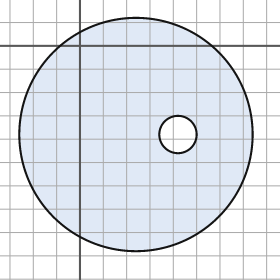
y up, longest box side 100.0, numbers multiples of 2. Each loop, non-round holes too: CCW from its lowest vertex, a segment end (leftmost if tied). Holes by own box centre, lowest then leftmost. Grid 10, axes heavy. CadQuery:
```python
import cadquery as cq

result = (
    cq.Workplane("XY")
    .moveTo(24.0, -38.0)
    .circle(50.0)
    .moveTo(42.0, -38.0)
    .circle(8.0)
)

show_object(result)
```